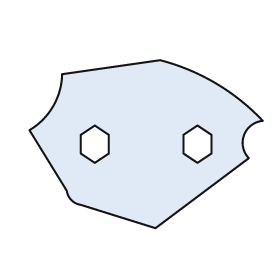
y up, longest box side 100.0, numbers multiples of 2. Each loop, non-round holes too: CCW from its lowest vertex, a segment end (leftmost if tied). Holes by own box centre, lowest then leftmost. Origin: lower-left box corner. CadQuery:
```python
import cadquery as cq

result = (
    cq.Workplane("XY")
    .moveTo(54.0, 0.0)
    .lineTo(94.0, 30.0)
    .threePointArc((92.0, 40.0), (100.0, 46.0))
    .threePointArc((80.0, 62.0), (56.0, 72.0))
    .lineTo(14.0, 66.0)
    .threePointArc((10.0, 52.0), (0.0, 42.0))
    .lineTo(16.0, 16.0)
    .threePointArc((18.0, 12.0), (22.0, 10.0))
    .close()
    .moveTo(28.0, 28.0)
    .lineTo(34.0, 32.0)
    .lineTo(34.0, 40.0)
    .lineTo(28.0, 44.0)
    .lineTo(22.0, 40.0)
    .lineTo(22.0, 32.0)
    .close()
    .moveTo(72.0, 28.0)
    .lineTo(78.0, 32.0)
    .lineTo(78.0, 40.0)
    .lineTo(72.0, 44.0)
    .lineTo(66.0, 40.0)
    .lineTo(66.0, 32.0)
    .close()
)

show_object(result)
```